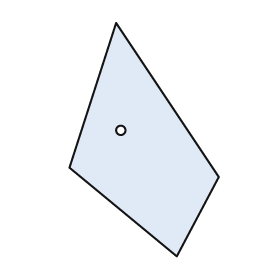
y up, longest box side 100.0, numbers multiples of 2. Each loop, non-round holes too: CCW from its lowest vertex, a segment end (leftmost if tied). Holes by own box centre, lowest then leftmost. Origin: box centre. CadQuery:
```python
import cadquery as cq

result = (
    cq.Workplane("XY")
    .moveTo(14.0, -50.0)
    .lineTo(32.0, -16.0)
    .lineTo(-12.0, 50.0)
    .lineTo(-32.0, -12.0)
    .close()
    .moveTo(-10.0, 4.0)
    .circle(2.0)
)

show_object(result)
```